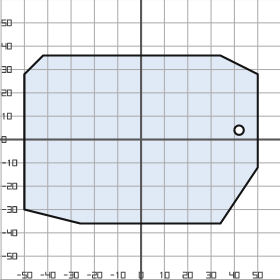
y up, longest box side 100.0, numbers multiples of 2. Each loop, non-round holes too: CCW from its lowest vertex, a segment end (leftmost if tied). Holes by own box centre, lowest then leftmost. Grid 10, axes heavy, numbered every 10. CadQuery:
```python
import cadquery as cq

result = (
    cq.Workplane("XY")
    .moveTo(-26.0, -36.0)
    .lineTo(34.0, -36.0)
    .lineTo(50.0, -12.0)
    .lineTo(50.0, 28.0)
    .lineTo(34.0, 36.0)
    .lineTo(-42.0, 36.0)
    .lineTo(-50.0, 28.0)
    .lineTo(-50.0, -30.0)
    .close()
    .moveTo(42.0, 4.0)
    .circle(2.0)
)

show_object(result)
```